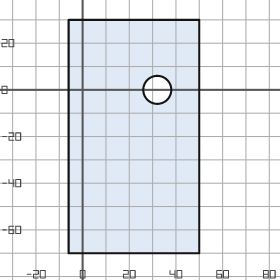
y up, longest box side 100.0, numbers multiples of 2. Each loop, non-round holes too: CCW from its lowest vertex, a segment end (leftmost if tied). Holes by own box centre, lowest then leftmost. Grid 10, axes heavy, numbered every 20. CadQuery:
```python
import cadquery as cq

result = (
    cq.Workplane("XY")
    .moveTo(-6.0, -70.0)
    .lineTo(50.0, -70.0)
    .lineTo(50.0, 30.0)
    .lineTo(-6.0, 30.0)
    .close()
    .moveTo(32.0, 0.0)
    .circle(6.0)
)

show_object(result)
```